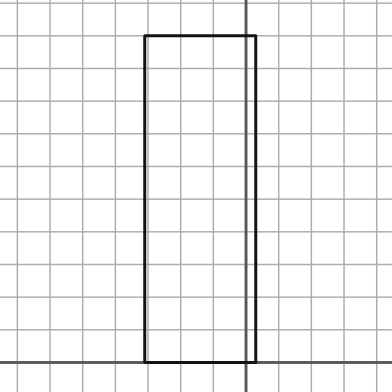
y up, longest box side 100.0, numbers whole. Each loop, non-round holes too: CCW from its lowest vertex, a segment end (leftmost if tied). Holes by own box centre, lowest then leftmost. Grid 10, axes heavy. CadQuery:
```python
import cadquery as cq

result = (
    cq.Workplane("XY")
    .moveTo(-31.0, 0.0)
    .lineTo(3.0, 0.0)
    .lineTo(3.0, 100.0)
    .lineTo(-31.0, 100.0)
    .close()
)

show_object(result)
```